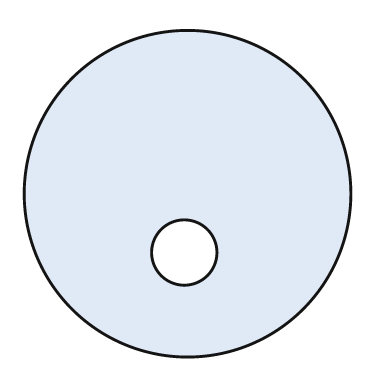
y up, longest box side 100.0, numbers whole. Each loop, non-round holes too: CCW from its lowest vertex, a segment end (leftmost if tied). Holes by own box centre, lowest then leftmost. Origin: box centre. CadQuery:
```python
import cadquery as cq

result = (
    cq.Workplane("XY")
    .moveTo(0.0, 0.0)
    .circle(50.0)
    .moveTo(-1.0, -18.0)
    .circle(10.0)
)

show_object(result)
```